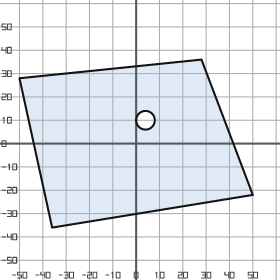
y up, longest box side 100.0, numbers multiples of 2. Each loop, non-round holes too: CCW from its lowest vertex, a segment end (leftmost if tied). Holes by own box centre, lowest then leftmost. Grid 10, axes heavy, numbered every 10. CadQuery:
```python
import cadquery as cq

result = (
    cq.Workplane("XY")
    .moveTo(-36.0, -36.0)
    .lineTo(50.0, -22.0)
    .lineTo(28.0, 36.0)
    .lineTo(-50.0, 28.0)
    .close()
    .moveTo(4.0, 10.0)
    .circle(4.0)
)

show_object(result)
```